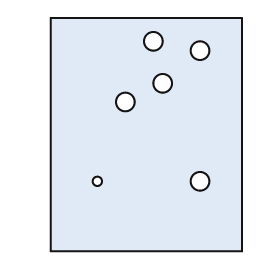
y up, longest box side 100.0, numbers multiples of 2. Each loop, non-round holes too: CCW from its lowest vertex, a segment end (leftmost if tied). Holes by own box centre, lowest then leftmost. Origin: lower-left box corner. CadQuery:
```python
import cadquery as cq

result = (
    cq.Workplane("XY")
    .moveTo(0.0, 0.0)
    .lineTo(82.0, 0.0)
    .lineTo(82.0, 100.0)
    .lineTo(0.0, 100.0)
    .close()
    .moveTo(20.0, 30.0)
    .circle(2.0)
    .moveTo(64.0, 30.0)
    .circle(4.0)
    .moveTo(32.0, 64.0)
    .circle(4.0)
    .moveTo(48.0, 72.0)
    .circle(4.0)
    .moveTo(64.0, 86.0)
    .circle(4.0)
    .moveTo(44.0, 90.0)
    .circle(4.0)
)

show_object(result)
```